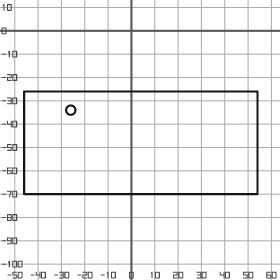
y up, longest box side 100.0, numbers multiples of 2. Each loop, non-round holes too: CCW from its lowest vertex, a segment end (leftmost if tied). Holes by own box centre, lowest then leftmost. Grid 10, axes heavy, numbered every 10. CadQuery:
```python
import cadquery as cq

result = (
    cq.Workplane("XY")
    .moveTo(-46.0, -70.0)
    .lineTo(54.0, -70.0)
    .lineTo(54.0, -26.0)
    .lineTo(-46.0, -26.0)
    .close()
    .moveTo(-26.0, -34.0)
    .circle(2.0)
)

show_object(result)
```